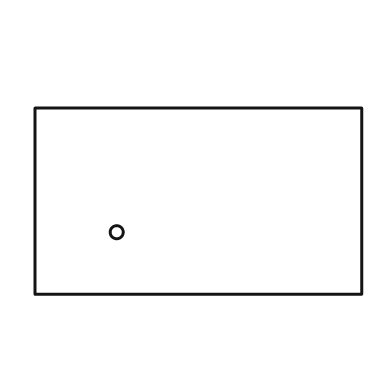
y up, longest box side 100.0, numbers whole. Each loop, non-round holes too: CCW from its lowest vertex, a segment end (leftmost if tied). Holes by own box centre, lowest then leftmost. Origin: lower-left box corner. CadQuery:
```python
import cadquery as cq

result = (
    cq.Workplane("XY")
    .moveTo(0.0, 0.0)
    .lineTo(100.0, 0.0)
    .lineTo(100.0, 57.0)
    .lineTo(0.0, 57.0)
    .close()
    .moveTo(25.0, 19.0)
    .circle(2.0)
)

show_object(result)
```